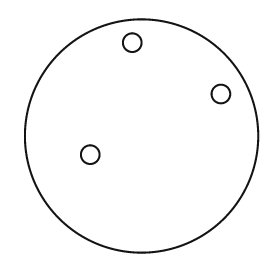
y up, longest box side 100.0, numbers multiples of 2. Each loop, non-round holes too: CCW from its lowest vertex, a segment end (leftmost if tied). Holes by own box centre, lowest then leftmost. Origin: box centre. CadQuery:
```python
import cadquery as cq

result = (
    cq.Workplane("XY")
    .moveTo(0.0, 0.0)
    .circle(50.0)
    .moveTo(-22.0, -8.0)
    .circle(4.0)
    .moveTo(34.0, 18.0)
    .circle(4.0)
    .moveTo(-4.0, 40.0)
    .circle(4.0)
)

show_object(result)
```